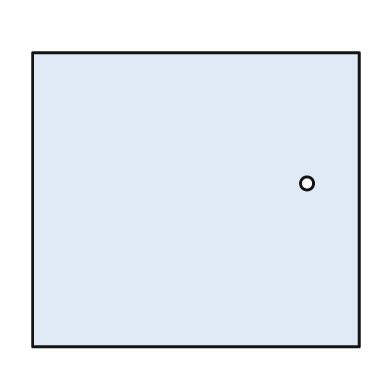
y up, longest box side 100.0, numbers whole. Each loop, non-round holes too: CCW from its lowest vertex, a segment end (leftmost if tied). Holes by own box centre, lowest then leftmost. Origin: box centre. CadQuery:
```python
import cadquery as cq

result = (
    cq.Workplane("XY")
    .moveTo(-50.0, -45.0)
    .lineTo(50.0, -45.0)
    .lineTo(50.0, 45.0)
    .lineTo(-50.0, 45.0)
    .close()
    .moveTo(34.0, 5.0)
    .circle(2.0)
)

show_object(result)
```